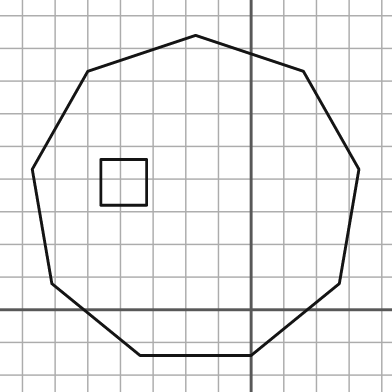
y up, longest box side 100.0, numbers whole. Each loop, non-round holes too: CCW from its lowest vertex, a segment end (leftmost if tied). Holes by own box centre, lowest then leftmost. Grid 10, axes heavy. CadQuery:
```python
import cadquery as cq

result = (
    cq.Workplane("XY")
    .moveTo(-34.0, -14.0)
    .lineTo(0.0, -14.0)
    .lineTo(27.0, 8.0)
    .lineTo(33.0, 43.0)
    .lineTo(16.0, 73.0)
    .lineTo(-17.0, 84.0)
    .lineTo(-50.0, 73.0)
    .lineTo(-67.0, 43.0)
    .lineTo(-61.0, 8.0)
    .close()
    .moveTo(-46.0, 32.0)
    .lineTo(-32.0, 32.0)
    .lineTo(-32.0, 46.0)
    .lineTo(-46.0, 46.0)
    .close()
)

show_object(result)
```